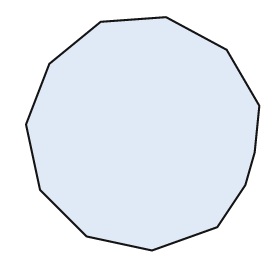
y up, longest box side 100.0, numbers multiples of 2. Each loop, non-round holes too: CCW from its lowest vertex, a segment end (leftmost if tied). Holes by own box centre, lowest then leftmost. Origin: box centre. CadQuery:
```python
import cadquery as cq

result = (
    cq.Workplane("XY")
    .moveTo(4.0, -50.0)
    .lineTo(32.0, -40.0)
    .lineTo(44.0, -22.0)
    .lineTo(48.0, -8.0)
    .lineTo(50.0, 12.0)
    .lineTo(36.0, 36.0)
    .lineTo(10.0, 50.0)
    .lineTo(-18.0, 48.0)
    .lineTo(-40.0, 30.0)
    .lineTo(-50.0, 4.0)
    .lineTo(-44.0, -24.0)
    .lineTo(-24.0, -44.0)
    .close()
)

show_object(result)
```